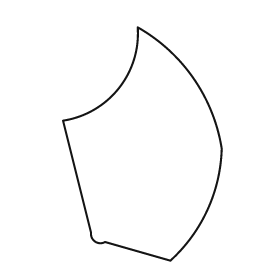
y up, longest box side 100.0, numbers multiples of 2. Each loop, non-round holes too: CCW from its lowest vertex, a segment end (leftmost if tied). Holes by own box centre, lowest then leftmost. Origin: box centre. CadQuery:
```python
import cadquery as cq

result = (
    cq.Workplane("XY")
    .moveTo(12.0, -50.0)
    .threePointArc((28.0, -28.0), (34.0, -2.0))
    .threePointArc((22.0, 28.0), (-2.0, 50.0))
    .threePointArc((-10.0, 24.0), (-34.0, 10.0))
    .lineTo(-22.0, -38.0)
    .threePointArc((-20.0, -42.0), (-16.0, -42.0))
    .close()
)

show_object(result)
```